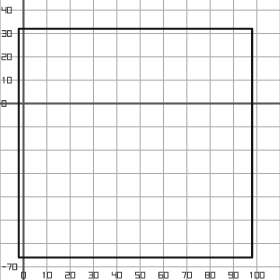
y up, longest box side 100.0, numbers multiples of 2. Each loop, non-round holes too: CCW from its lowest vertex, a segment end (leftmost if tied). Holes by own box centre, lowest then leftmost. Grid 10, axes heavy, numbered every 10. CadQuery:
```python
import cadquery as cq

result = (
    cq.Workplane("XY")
    .moveTo(-2.0, -66.0)
    .lineTo(98.0, -66.0)
    .lineTo(98.0, 32.0)
    .lineTo(-2.0, 32.0)
    .close()
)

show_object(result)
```